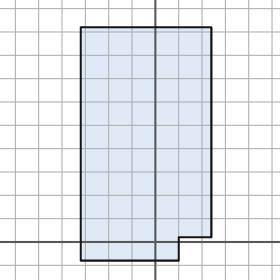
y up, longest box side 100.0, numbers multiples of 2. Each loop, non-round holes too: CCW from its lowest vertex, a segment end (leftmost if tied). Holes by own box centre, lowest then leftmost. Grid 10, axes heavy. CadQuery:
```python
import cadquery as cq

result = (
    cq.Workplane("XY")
    .moveTo(-32.0, -8.0)
    .lineTo(10.0, -8.0)
    .lineTo(10.0, 2.0)
    .lineTo(24.0, 2.0)
    .lineTo(24.0, 92.0)
    .lineTo(-32.0, 92.0)
    .close()
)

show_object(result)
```